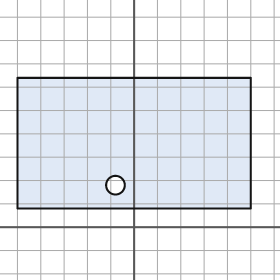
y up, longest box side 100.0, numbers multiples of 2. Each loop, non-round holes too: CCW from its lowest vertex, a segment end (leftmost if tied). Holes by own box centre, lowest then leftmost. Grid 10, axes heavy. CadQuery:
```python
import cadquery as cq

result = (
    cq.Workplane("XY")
    .moveTo(-50.0, 8.0)
    .lineTo(50.0, 8.0)
    .lineTo(50.0, 64.0)
    .lineTo(-50.0, 64.0)
    .close()
    .moveTo(-8.0, 18.0)
    .circle(4.0)
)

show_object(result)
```